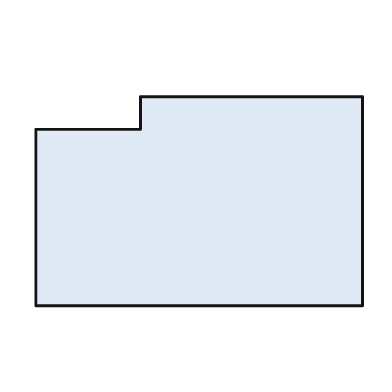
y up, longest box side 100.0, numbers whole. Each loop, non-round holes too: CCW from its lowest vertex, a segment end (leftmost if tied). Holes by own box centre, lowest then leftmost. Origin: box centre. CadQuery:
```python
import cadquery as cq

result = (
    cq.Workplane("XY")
    .moveTo(-50.0, -32.0)
    .lineTo(50.0, -32.0)
    .lineTo(50.0, 32.0)
    .lineTo(-18.0, 32.0)
    .lineTo(-18.0, 22.0)
    .lineTo(-50.0, 22.0)
    .close()
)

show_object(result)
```